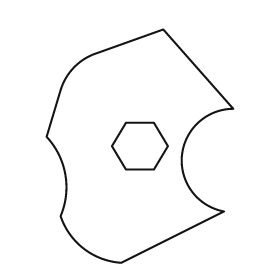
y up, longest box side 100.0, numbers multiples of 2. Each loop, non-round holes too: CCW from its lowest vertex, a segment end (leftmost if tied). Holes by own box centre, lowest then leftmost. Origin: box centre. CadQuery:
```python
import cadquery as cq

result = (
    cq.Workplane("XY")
    .moveTo(-8.0, -50.0)
    .lineTo(36.0, -28.0)
    .threePointArc((18.0, -4.0), (40.0, 16.0))
    .lineTo(10.0, 50.0)
    .lineTo(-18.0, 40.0)
    .threePointArc((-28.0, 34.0), (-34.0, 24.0))
    .lineTo(-40.0, 4.0)
    .threePointArc((-32.0, -12.0), (-34.0, -30.0))
    .threePointArc((-24.0, -44.0), (-8.0, -50.0))
    .close()
    .moveTo(-6.0, -10.0)
    .lineTo(6.0, -10.0)
    .lineTo(12.0, 0.0)
    .lineTo(6.0, 10.0)
    .lineTo(-6.0, 10.0)
    .lineTo(-12.0, 0.0)
    .close()
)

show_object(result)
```